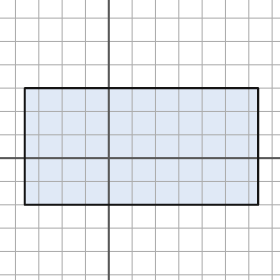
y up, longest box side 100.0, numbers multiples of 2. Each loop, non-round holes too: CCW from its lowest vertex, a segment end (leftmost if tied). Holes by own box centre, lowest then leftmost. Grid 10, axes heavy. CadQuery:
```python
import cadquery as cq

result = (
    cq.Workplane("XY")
    .moveTo(-36.0, -20.0)
    .lineTo(64.0, -20.0)
    .lineTo(64.0, 30.0)
    .lineTo(-36.0, 30.0)
    .close()
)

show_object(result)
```